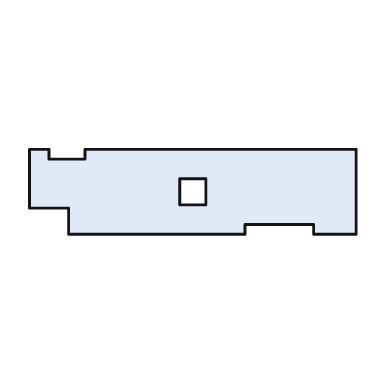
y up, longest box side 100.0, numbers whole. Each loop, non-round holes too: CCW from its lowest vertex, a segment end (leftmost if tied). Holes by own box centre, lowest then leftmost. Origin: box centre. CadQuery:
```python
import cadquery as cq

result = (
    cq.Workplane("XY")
    .moveTo(-38.0, -13.0)
    .lineTo(16.0, -13.0)
    .lineTo(16.0, -10.0)
    .lineTo(37.0, -10.0)
    .lineTo(37.0, -13.0)
    .lineTo(50.0, -13.0)
    .lineTo(50.0, 13.0)
    .lineTo(-33.0, 13.0)
    .lineTo(-33.0, 10.0)
    .lineTo(-44.0, 10.0)
    .lineTo(-44.0, 13.0)
    .lineTo(-50.0, 13.0)
    .lineTo(-50.0, -5.0)
    .lineTo(-38.0, -5.0)
    .close()
    .moveTo(-4.0, -4.0)
    .lineTo(4.0, -4.0)
    .lineTo(4.0, 4.0)
    .lineTo(-4.0, 4.0)
    .close()
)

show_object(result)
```